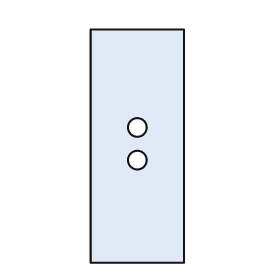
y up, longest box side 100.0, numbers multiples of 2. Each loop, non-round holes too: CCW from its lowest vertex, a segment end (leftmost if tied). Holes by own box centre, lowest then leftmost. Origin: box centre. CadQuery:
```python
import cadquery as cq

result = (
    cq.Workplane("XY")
    .moveTo(-20.0, -50.0)
    .lineTo(20.0, -50.0)
    .lineTo(20.0, 50.0)
    .lineTo(-20.0, 50.0)
    .close()
    .moveTo(0.0, -6.0)
    .circle(4.0)
    .moveTo(0.0, 8.0)
    .circle(4.0)
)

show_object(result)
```